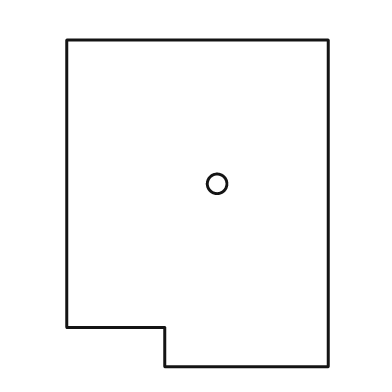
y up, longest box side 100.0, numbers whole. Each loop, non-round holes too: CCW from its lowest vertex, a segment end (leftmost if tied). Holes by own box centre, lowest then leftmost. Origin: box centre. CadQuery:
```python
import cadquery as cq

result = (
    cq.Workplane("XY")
    .moveTo(-10.0, -50.0)
    .lineTo(40.0, -50.0)
    .lineTo(40.0, 50.0)
    .lineTo(-40.0, 50.0)
    .lineTo(-40.0, -38.0)
    .lineTo(-10.0, -38.0)
    .close()
    .moveTo(6.0, 6.0)
    .circle(3.0)
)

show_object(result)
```